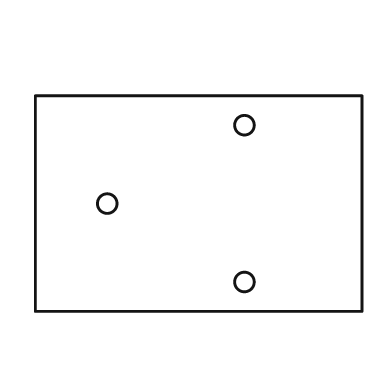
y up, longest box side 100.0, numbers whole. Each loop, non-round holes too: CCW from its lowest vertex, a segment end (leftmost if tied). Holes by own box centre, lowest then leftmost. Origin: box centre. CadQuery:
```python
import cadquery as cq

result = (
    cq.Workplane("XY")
    .moveTo(-50.0, -33.0)
    .lineTo(50.0, -33.0)
    .lineTo(50.0, 33.0)
    .lineTo(-50.0, 33.0)
    .close()
    .moveTo(14.0, -24.0)
    .circle(3.0)
    .moveTo(-28.0, 0.0)
    .circle(3.0)
    .moveTo(14.0, 24.0)
    .circle(3.0)
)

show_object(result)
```